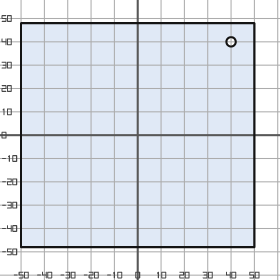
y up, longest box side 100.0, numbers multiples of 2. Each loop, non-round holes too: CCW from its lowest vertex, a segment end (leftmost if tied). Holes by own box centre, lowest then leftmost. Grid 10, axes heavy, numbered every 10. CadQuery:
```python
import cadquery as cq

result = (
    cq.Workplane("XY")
    .moveTo(-50.0, -48.0)
    .lineTo(50.0, -48.0)
    .lineTo(50.0, 48.0)
    .lineTo(-50.0, 48.0)
    .close()
    .moveTo(40.0, 40.0)
    .circle(2.0)
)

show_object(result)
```